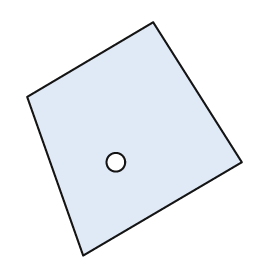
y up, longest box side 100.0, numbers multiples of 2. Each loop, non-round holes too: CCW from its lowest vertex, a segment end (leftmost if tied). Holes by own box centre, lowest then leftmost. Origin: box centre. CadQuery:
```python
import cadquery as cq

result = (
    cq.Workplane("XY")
    .moveTo(-22.0, -50.0)
    .lineTo(46.0, -10.0)
    .lineTo(8.0, 50.0)
    .lineTo(-46.0, 18.0)
    .close()
    .moveTo(-8.0, -10.0)
    .circle(4.0)
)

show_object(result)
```